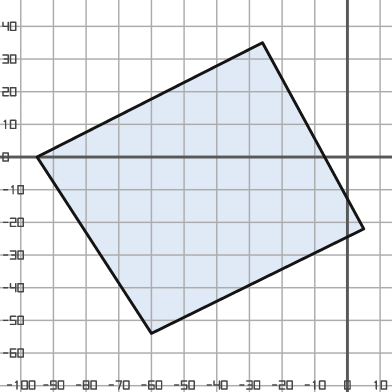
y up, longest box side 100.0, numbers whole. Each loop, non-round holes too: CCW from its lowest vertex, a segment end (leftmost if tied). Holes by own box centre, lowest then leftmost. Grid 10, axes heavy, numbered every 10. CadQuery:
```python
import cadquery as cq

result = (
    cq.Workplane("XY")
    .moveTo(-60.0, -54.0)
    .lineTo(5.0, -22.0)
    .lineTo(-26.0, 35.0)
    .lineTo(-95.0, 0.0)
    .close()
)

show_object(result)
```